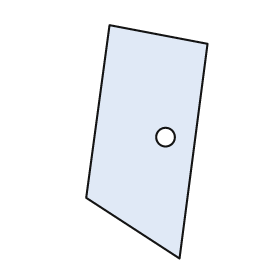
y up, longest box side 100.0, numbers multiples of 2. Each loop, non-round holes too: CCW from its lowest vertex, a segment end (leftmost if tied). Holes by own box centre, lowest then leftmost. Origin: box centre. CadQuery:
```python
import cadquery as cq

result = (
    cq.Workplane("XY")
    .moveTo(14.0, -50.0)
    .lineTo(26.0, 42.0)
    .lineTo(-16.0, 50.0)
    .lineTo(-26.0, -24.0)
    .close()
    .moveTo(8.0, 2.0)
    .circle(4.0)
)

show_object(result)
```